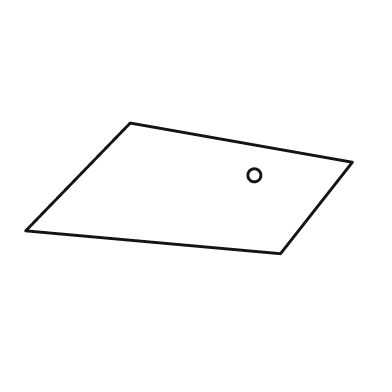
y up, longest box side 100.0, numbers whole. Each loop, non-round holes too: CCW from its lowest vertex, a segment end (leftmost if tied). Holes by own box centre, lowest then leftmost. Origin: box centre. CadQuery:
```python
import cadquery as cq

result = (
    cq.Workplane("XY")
    .moveTo(28.0, -20.0)
    .lineTo(50.0, 8.0)
    .lineTo(-18.0, 20.0)
    .lineTo(-50.0, -13.0)
    .close()
    .moveTo(20.0, 4.0)
    .circle(2.0)
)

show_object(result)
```